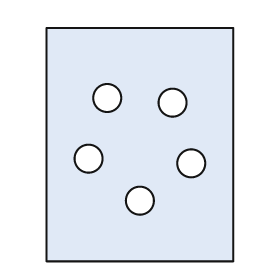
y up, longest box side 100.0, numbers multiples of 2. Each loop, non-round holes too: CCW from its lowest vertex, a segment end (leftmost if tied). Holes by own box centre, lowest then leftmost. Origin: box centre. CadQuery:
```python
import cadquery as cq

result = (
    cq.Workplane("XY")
    .moveTo(-40.0, -50.0)
    .lineTo(40.0, -50.0)
    .lineTo(40.0, 50.0)
    .lineTo(-40.0, 50.0)
    .close()
    .moveTo(0.0, -24.0)
    .circle(6.0)
    .moveTo(22.0, -8.0)
    .circle(6.0)
    .moveTo(-22.0, -6.0)
    .circle(6.0)
    .moveTo(14.0, 18.0)
    .circle(6.0)
    .moveTo(-14.0, 20.0)
    .circle(6.0)
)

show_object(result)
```